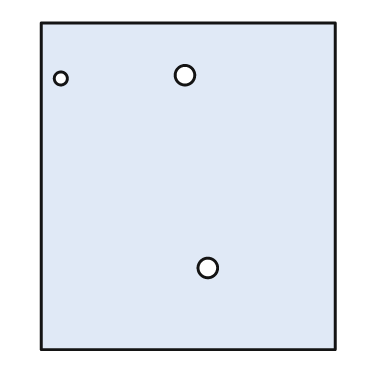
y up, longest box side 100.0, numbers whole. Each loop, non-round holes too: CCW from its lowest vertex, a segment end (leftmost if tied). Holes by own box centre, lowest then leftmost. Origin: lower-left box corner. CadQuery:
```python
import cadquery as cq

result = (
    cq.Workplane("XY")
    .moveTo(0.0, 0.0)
    .lineTo(90.0, 0.0)
    .lineTo(90.0, 100.0)
    .lineTo(0.0, 100.0)
    .close()
    .moveTo(51.0, 25.0)
    .circle(3.0)
    .moveTo(6.0, 83.0)
    .circle(2.0)
    .moveTo(44.0, 84.0)
    .circle(3.0)
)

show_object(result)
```